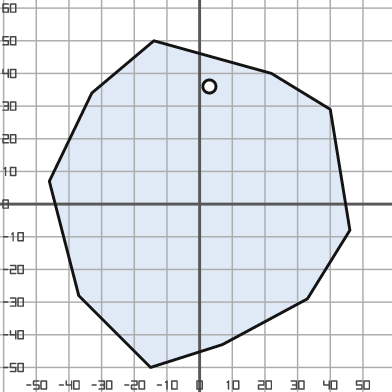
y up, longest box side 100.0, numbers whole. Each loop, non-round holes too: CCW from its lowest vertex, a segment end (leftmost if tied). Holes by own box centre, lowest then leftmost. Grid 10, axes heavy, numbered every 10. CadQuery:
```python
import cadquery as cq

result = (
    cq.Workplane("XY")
    .moveTo(-15.0, -50.0)
    .lineTo(7.0, -43.0)
    .lineTo(33.0, -29.0)
    .lineTo(46.0, -8.0)
    .lineTo(40.0, 29.0)
    .lineTo(22.0, 40.0)
    .lineTo(-14.0, 50.0)
    .lineTo(-33.0, 34.0)
    .lineTo(-46.0, 7.0)
    .lineTo(-37.0, -28.0)
    .close()
    .moveTo(3.0, 36.0)
    .circle(2.0)
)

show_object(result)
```